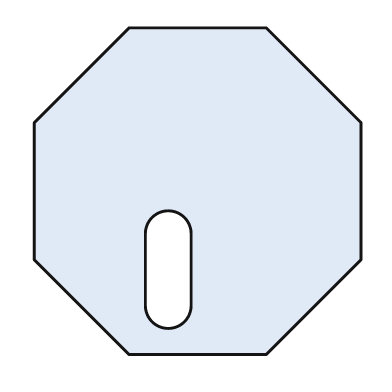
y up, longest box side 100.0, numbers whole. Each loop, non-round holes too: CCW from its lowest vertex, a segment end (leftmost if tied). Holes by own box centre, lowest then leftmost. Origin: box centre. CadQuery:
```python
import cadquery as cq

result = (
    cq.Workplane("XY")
    .moveTo(-21.0, -50.0)
    .lineTo(21.0, -50.0)
    .lineTo(50.0, -21.0)
    .lineTo(50.0, 21.0)
    .lineTo(21.0, 50.0)
    .lineTo(-21.0, 50.0)
    .lineTo(-50.0, 21.0)
    .lineTo(-50.0, -21.0)
    .close()
    .moveTo(-16.0, -35.0)
    .threePointArc((-9.0, -42.0), (-2.0, -35.0))
    .lineTo(-2.0, -13.0)
    .threePointArc((-9.0, -6.0), (-16.0, -13.0))
    .close()
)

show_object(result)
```